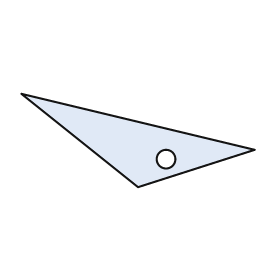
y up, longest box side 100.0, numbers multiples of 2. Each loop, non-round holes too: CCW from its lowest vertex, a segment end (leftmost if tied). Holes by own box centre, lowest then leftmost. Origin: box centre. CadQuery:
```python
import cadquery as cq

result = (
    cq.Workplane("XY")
    .moveTo(0.0, -20.0)
    .lineTo(50.0, -4.0)
    .lineTo(-50.0, 20.0)
    .close()
    .moveTo(12.0, -8.0)
    .circle(4.0)
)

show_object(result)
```